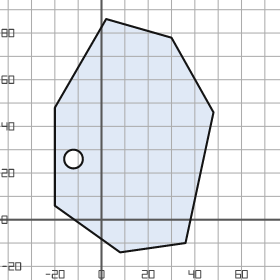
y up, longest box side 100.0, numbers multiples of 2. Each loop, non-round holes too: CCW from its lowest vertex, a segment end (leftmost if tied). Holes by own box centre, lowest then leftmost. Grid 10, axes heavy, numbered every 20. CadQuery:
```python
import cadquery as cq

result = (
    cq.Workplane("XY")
    .moveTo(8.0, -14.0)
    .lineTo(36.0, -10.0)
    .lineTo(48.0, 46.0)
    .lineTo(30.0, 78.0)
    .lineTo(2.0, 86.0)
    .lineTo(-20.0, 48.0)
    .lineTo(-20.0, 6.0)
    .close()
    .moveTo(-12.0, 26.0)
    .circle(4.0)
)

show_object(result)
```